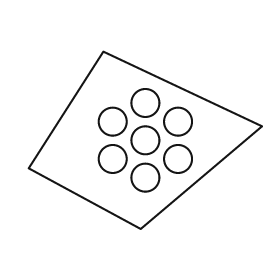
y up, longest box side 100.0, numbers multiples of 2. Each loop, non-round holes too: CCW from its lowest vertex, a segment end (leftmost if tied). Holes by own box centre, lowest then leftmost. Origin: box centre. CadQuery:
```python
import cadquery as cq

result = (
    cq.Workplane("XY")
    .moveTo(-2.0, -38.0)
    .lineTo(50.0, 6.0)
    .lineTo(-18.0, 38.0)
    .lineTo(-50.0, -12.0)
    .close()
    .moveTo(0.0, -16.0)
    .circle(6.0)
    .moveTo(-14.0, -8.0)
    .circle(6.0)
    .moveTo(14.0, -8.0)
    .circle(6.0)
    .moveTo(0.0, 0.0)
    .circle(6.0)
    .moveTo(-14.0, 8.0)
    .circle(6.0)
    .moveTo(14.0, 8.0)
    .circle(6.0)
    .moveTo(0.0, 16.0)
    .circle(6.0)
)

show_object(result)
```